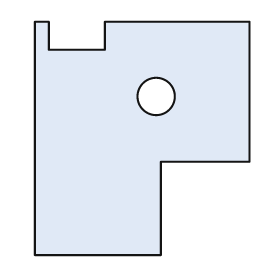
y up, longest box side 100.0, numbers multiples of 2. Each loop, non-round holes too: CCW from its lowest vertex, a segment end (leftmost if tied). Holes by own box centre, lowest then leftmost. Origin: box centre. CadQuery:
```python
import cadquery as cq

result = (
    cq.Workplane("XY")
    .moveTo(-46.0, -50.0)
    .lineTo(8.0, -50.0)
    .lineTo(8.0, -10.0)
    .lineTo(46.0, -10.0)
    .lineTo(46.0, 50.0)
    .lineTo(-16.0, 50.0)
    .lineTo(-16.0, 38.0)
    .lineTo(-40.0, 38.0)
    .lineTo(-40.0, 50.0)
    .lineTo(-46.0, 50.0)
    .close()
    .moveTo(6.0, 18.0)
    .circle(8.0)
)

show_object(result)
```